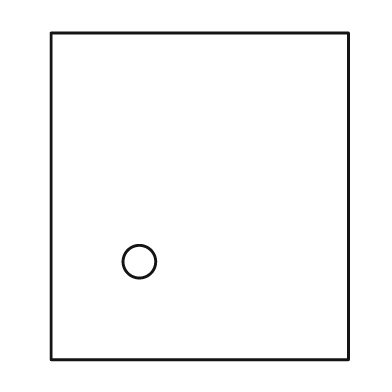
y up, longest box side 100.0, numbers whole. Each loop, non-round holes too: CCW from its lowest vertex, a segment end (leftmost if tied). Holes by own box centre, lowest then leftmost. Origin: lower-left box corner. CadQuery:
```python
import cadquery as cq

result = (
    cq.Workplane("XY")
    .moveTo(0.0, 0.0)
    .lineTo(91.0, 0.0)
    .lineTo(91.0, 100.0)
    .lineTo(0.0, 100.0)
    .close()
    .moveTo(27.0, 30.0)
    .circle(5.0)
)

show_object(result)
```